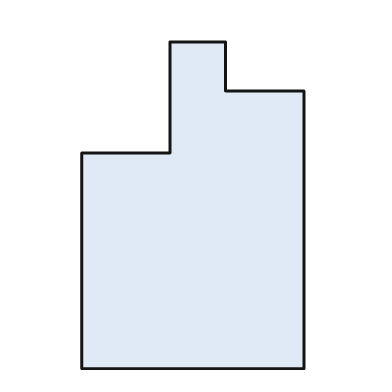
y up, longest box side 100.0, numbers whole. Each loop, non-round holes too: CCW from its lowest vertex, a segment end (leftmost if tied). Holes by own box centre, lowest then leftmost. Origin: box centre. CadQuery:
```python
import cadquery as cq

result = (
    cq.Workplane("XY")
    .moveTo(-34.0, -50.0)
    .lineTo(34.0, -50.0)
    .lineTo(34.0, 35.0)
    .lineTo(10.0, 35.0)
    .lineTo(10.0, 50.0)
    .lineTo(-7.0, 50.0)
    .lineTo(-7.0, 16.0)
    .lineTo(-34.0, 16.0)
    .close()
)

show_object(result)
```